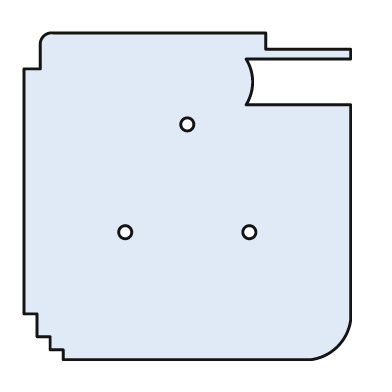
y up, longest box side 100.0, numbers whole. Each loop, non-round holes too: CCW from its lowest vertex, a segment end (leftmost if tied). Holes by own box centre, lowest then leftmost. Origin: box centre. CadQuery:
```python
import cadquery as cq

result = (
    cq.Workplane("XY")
    .moveTo(-38.0, -50.0)
    .lineTo(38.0, -50.0)
    .threePointArc((46.0, -46.0), (50.0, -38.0))
    .lineTo(50.0, 28.0)
    .lineTo(18.0, 28.0)
    .threePointArc((20.0, 35.0), (18.0, 42.0))
    .lineTo(50.0, 42.0)
    .lineTo(50.0, 45.0)
    .lineTo(24.0, 45.0)
    .lineTo(24.0, 50.0)
    .lineTo(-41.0, 50.0)
    .threePointArc((-44.0, 49.0), (-45.0, 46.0))
    .lineTo(-45.0, 39.0)
    .lineTo(-50.0, 39.0)
    .lineTo(-50.0, -36.0)
    .lineTo(-46.0, -36.0)
    .lineTo(-46.0, -43.0)
    .lineTo(-42.0, -43.0)
    .lineTo(-42.0, -47.0)
    .lineTo(-38.0, -47.0)
    .close()
    .moveTo(-19.0, -11.0)
    .circle(2.0)
    .moveTo(19.0, -11.0)
    .circle(2.0)
    .moveTo(0.0, 22.0)
    .circle(2.0)
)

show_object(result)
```